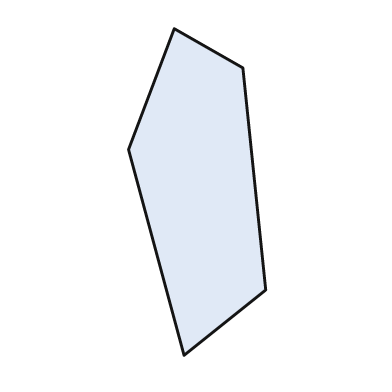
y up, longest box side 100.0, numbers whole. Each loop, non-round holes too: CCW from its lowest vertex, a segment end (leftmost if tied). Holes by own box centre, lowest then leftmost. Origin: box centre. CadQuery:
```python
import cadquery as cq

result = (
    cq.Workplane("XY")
    .moveTo(-4.0, -50.0)
    .lineTo(21.0, -30.0)
    .lineTo(14.0, 38.0)
    .lineTo(-7.0, 50.0)
    .lineTo(-21.0, 13.0)
    .close()
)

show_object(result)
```